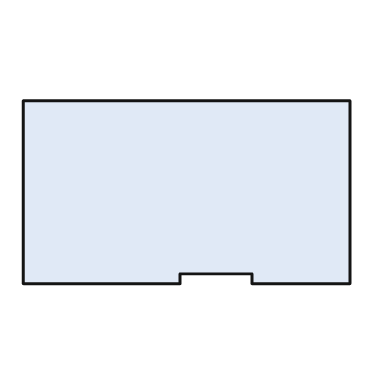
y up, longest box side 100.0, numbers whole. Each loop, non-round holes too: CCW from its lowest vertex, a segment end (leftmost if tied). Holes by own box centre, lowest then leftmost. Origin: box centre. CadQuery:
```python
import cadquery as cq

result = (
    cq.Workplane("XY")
    .moveTo(-50.0, -28.0)
    .lineTo(-2.0, -28.0)
    .lineTo(-2.0, -25.0)
    .lineTo(20.0, -25.0)
    .lineTo(20.0, -28.0)
    .lineTo(50.0, -28.0)
    .lineTo(50.0, 28.0)
    .lineTo(-50.0, 28.0)
    .close()
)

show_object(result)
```